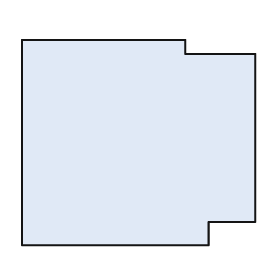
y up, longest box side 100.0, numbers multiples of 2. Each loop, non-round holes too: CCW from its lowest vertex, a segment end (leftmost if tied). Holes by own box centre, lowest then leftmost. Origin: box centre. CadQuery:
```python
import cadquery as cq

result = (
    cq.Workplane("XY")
    .moveTo(-50.0, -44.0)
    .lineTo(30.0, -44.0)
    .lineTo(30.0, -34.0)
    .lineTo(50.0, -34.0)
    .lineTo(50.0, 38.0)
    .lineTo(20.0, 38.0)
    .lineTo(20.0, 44.0)
    .lineTo(-50.0, 44.0)
    .close()
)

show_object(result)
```